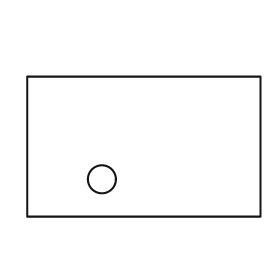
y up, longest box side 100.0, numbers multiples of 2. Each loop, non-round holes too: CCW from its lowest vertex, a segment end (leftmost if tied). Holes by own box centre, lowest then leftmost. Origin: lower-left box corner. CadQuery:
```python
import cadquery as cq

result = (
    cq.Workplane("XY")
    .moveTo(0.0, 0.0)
    .lineTo(100.0, 0.0)
    .lineTo(100.0, 60.0)
    .lineTo(0.0, 60.0)
    .close()
    .moveTo(32.0, 16.0)
    .circle(6.0)
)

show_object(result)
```